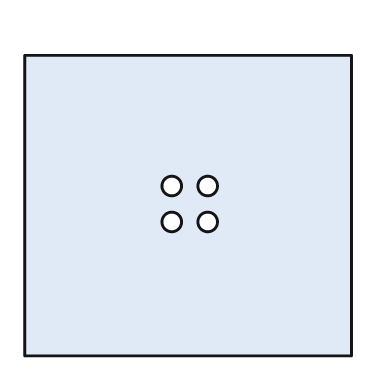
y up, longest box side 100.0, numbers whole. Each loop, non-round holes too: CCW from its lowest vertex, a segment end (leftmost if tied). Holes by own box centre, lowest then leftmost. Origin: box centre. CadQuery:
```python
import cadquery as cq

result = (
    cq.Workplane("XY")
    .moveTo(-50.0, -46.0)
    .lineTo(50.0, -46.0)
    .lineTo(50.0, 46.0)
    .lineTo(-50.0, 46.0)
    .close()
    .moveTo(-5.0, -5.0)
    .circle(3.0)
    .moveTo(6.0, -5.0)
    .circle(3.0)
    .moveTo(-5.0, 6.0)
    .circle(3.0)
    .moveTo(6.0, 6.0)
    .circle(3.0)
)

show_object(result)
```